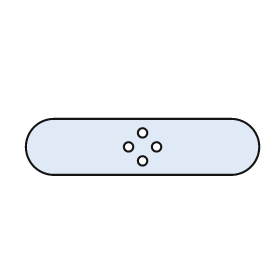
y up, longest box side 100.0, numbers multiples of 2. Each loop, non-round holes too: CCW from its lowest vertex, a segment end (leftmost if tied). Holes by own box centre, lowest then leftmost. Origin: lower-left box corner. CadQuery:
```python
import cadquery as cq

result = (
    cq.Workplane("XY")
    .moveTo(12.0, 0.0)
    .lineTo(88.0, 0.0)
    .threePointArc((100.0, 12.0), (88.0, 24.0))
    .lineTo(12.0, 24.0)
    .threePointArc((0.0, 12.0), (12.0, 0.0))
    .close()
    .moveTo(50.0, 6.0)
    .circle(2.0)
    .moveTo(44.0, 12.0)
    .circle(2.0)
    .moveTo(56.0, 12.0)
    .circle(2.0)
    .moveTo(50.0, 18.0)
    .circle(2.0)
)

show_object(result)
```